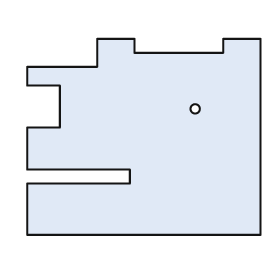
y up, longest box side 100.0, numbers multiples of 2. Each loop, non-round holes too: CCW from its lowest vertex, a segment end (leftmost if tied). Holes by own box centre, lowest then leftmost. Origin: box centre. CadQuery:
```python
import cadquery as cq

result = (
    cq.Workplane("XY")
    .moveTo(-50.0, -42.0)
    .lineTo(50.0, -42.0)
    .lineTo(50.0, 42.0)
    .lineTo(34.0, 42.0)
    .lineTo(34.0, 36.0)
    .lineTo(-4.0, 36.0)
    .lineTo(-4.0, 42.0)
    .lineTo(-20.0, 42.0)
    .lineTo(-20.0, 30.0)
    .lineTo(-50.0, 30.0)
    .lineTo(-50.0, 22.0)
    .lineTo(-36.0, 22.0)
    .lineTo(-36.0, 4.0)
    .lineTo(-50.0, 4.0)
    .lineTo(-50.0, -14.0)
    .lineTo(-6.0, -14.0)
    .lineTo(-6.0, -20.0)
    .lineTo(-50.0, -20.0)
    .close()
    .moveTo(22.0, 12.0)
    .circle(2.0)
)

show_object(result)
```